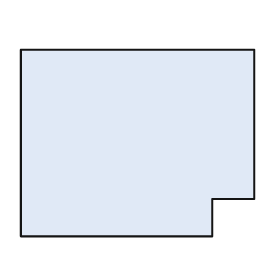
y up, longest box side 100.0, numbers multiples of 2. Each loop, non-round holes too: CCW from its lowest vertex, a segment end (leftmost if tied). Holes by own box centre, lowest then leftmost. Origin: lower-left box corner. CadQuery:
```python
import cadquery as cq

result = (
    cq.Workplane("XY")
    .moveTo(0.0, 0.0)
    .lineTo(82.0, 0.0)
    .lineTo(82.0, 16.0)
    .lineTo(100.0, 16.0)
    .lineTo(100.0, 80.0)
    .lineTo(0.0, 80.0)
    .close()
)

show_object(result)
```